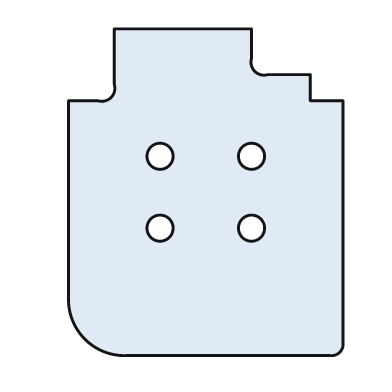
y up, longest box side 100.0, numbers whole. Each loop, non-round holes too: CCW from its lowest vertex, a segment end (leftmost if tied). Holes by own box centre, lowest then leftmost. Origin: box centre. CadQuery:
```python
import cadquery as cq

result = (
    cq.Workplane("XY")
    .moveTo(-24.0, -50.0)
    .lineTo(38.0, -50.0)
    .threePointArc((41.0, -49.0), (42.0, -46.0))
    .lineTo(42.0, 28.0)
    .lineTo(32.0, 28.0)
    .lineTo(32.0, 36.0)
    .lineTo(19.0, 36.0)
    .threePointArc((15.0, 37.0), (14.0, 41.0))
    .lineTo(14.0, 50.0)
    .lineTo(-28.0, 50.0)
    .lineTo(-28.0, 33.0)
    .threePointArc((-29.0, 29.0), (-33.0, 28.0))
    .lineTo(-42.0, 28.0)
    .lineTo(-42.0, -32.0)
    .threePointArc((-37.0, -45.0), (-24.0, -50.0))
    .close()
    .moveTo(-14.0, -11.0)
    .circle(4.0)
    .moveTo(14.0, -11.0)
    .circle(4.0)
    .moveTo(-14.0, 11.0)
    .circle(4.0)
    .moveTo(14.0, 11.0)
    .circle(4.0)
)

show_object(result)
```